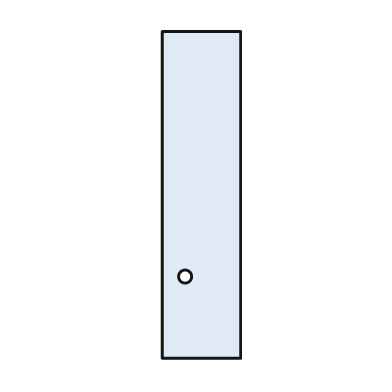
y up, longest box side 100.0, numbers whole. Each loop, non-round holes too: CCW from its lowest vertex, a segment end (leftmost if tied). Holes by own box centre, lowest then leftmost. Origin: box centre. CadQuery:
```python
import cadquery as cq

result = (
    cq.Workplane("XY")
    .moveTo(-12.0, -50.0)
    .lineTo(12.0, -50.0)
    .lineTo(12.0, 50.0)
    .lineTo(-12.0, 50.0)
    .close()
    .moveTo(-5.0, -25.0)
    .circle(2.0)
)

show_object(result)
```